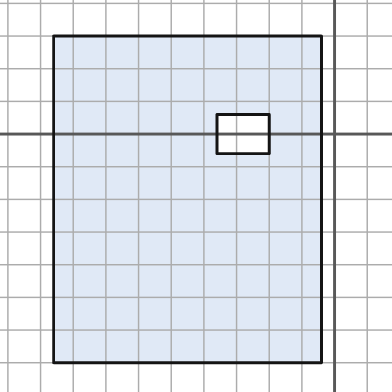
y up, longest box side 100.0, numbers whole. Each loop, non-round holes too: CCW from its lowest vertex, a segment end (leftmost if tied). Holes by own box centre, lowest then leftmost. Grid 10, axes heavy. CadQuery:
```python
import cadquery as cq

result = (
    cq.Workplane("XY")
    .moveTo(-86.0, -70.0)
    .lineTo(-4.0, -70.0)
    .lineTo(-4.0, 30.0)
    .lineTo(-86.0, 30.0)
    .close()
    .moveTo(-36.0, -6.0)
    .lineTo(-20.0, -6.0)
    .lineTo(-20.0, 6.0)
    .lineTo(-36.0, 6.0)
    .close()
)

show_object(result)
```